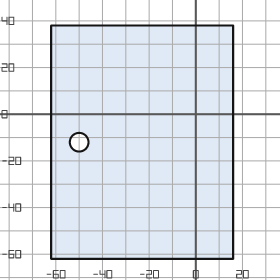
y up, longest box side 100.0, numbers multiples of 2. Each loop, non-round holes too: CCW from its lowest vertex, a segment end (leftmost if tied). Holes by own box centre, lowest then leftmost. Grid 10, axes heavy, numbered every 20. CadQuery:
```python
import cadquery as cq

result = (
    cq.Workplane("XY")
    .moveTo(-62.0, -62.0)
    .lineTo(16.0, -62.0)
    .lineTo(16.0, 38.0)
    .lineTo(-62.0, 38.0)
    .close()
    .moveTo(-50.0, -12.0)
    .circle(4.0)
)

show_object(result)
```